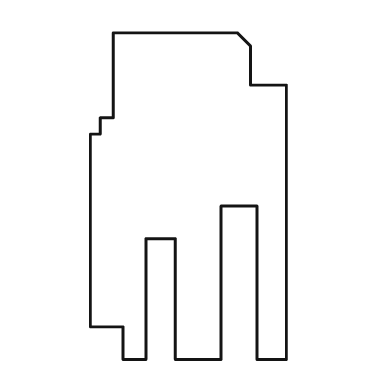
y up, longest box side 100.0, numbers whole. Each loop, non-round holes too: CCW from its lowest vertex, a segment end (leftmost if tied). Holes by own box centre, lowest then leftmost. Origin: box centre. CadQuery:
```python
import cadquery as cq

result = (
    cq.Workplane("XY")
    .moveTo(-20.0, -50.0)
    .lineTo(-13.0, -50.0)
    .lineTo(-13.0, -13.0)
    .lineTo(-4.0, -13.0)
    .lineTo(-4.0, -50.0)
    .lineTo(10.0, -50.0)
    .lineTo(10.0, -3.0)
    .lineTo(21.0, -3.0)
    .lineTo(21.0, -50.0)
    .lineTo(30.0, -50.0)
    .lineTo(30.0, 34.0)
    .lineTo(19.0, 34.0)
    .lineTo(19.0, 46.0)
    .lineTo(15.0, 50.0)
    .lineTo(-23.0, 50.0)
    .lineTo(-23.0, 24.0)
    .lineTo(-27.0, 24.0)
    .lineTo(-27.0, 19.0)
    .lineTo(-30.0, 19.0)
    .lineTo(-30.0, -40.0)
    .lineTo(-20.0, -40.0)
    .close()
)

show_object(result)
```